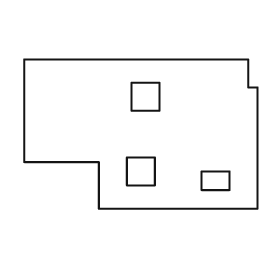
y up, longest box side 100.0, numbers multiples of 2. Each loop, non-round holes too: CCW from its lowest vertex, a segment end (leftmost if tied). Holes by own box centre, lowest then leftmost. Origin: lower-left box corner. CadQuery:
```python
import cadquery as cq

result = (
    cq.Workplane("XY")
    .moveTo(32.0, 0.0)
    .lineTo(100.0, 0.0)
    .lineTo(100.0, 52.0)
    .lineTo(96.0, 52.0)
    .lineTo(96.0, 64.0)
    .lineTo(0.0, 64.0)
    .lineTo(0.0, 20.0)
    .lineTo(32.0, 20.0)
    .close()
    .moveTo(76.0, 8.0)
    .lineTo(88.0, 8.0)
    .lineTo(88.0, 16.0)
    .lineTo(76.0, 16.0)
    .close()
    .moveTo(44.0, 10.0)
    .lineTo(56.0, 10.0)
    .lineTo(56.0, 22.0)
    .lineTo(44.0, 22.0)
    .close()
    .moveTo(46.0, 42.0)
    .lineTo(58.0, 42.0)
    .lineTo(58.0, 54.0)
    .lineTo(46.0, 54.0)
    .close()
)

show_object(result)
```